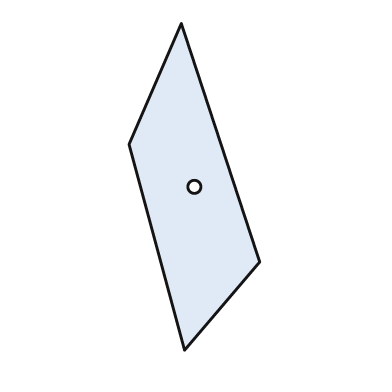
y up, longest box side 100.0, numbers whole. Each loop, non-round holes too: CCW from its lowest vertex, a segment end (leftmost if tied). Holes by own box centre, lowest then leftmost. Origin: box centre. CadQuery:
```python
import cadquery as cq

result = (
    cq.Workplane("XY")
    .moveTo(-3.0, -50.0)
    .lineTo(20.0, -23.0)
    .lineTo(-4.0, 50.0)
    .lineTo(-20.0, 13.0)
    .close()
    .moveTo(0.0, 0.0)
    .circle(2.0)
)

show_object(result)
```